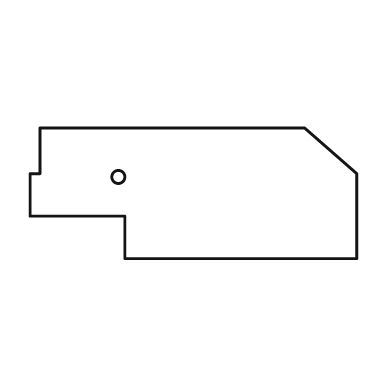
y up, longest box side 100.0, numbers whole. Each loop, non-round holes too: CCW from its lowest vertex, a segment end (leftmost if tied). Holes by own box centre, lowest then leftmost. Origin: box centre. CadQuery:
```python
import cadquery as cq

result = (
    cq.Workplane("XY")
    .moveTo(-21.0, -20.0)
    .lineTo(50.0, -20.0)
    .lineTo(50.0, 6.0)
    .lineTo(34.0, 20.0)
    .lineTo(-47.0, 20.0)
    .lineTo(-47.0, 6.0)
    .lineTo(-50.0, 6.0)
    .lineTo(-50.0, -7.0)
    .lineTo(-21.0, -7.0)
    .close()
    .moveTo(-23.0, 5.0)
    .circle(2.0)
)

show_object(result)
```